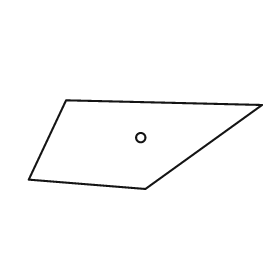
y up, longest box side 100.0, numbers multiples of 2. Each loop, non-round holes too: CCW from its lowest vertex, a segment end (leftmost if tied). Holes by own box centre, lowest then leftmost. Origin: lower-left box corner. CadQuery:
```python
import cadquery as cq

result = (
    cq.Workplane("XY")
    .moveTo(50.0, 0.0)
    .lineTo(100.0, 36.0)
    .lineTo(16.0, 38.0)
    .lineTo(0.0, 4.0)
    .close()
    .moveTo(48.0, 22.0)
    .circle(2.0)
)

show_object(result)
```